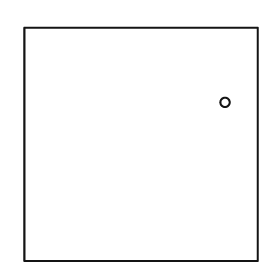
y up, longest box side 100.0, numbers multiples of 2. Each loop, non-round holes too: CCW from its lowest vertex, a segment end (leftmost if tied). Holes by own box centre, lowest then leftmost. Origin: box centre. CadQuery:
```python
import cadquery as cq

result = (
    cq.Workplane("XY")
    .moveTo(-50.0, -50.0)
    .lineTo(50.0, -50.0)
    .lineTo(50.0, 50.0)
    .lineTo(-50.0, 50.0)
    .close()
    .moveTo(36.0, 18.0)
    .circle(2.0)
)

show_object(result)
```